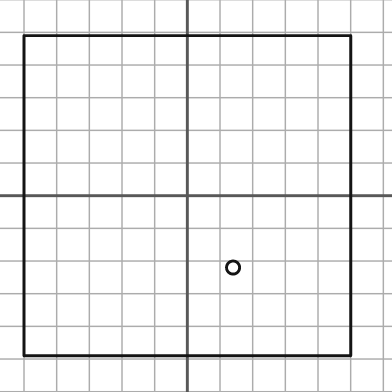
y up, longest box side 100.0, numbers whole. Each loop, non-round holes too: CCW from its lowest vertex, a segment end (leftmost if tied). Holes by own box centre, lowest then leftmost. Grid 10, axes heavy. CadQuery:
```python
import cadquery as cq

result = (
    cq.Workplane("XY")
    .moveTo(-50.0, -49.0)
    .lineTo(50.0, -49.0)
    .lineTo(50.0, 49.0)
    .lineTo(-50.0, 49.0)
    .close()
    .moveTo(14.0, -22.0)
    .circle(2.0)
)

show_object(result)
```